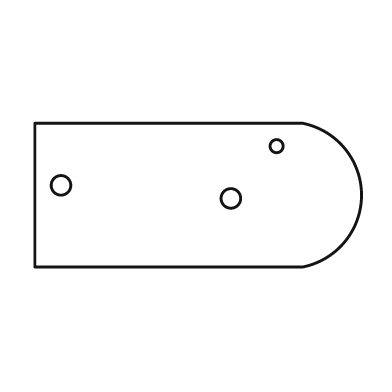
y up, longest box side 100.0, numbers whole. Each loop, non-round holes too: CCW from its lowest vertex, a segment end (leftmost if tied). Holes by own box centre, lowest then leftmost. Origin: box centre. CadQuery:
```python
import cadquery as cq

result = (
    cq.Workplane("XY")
    .moveTo(-50.0, -22.0)
    .lineTo(32.0, -22.0)
    .threePointArc((50.0, 0.0), (32.0, 22.0))
    .lineTo(-50.0, 22.0)
    .close()
    .moveTo(10.0, -1.0)
    .circle(3.0)
    .moveTo(-42.0, 3.0)
    .circle(3.0)
    .moveTo(24.0, 15.0)
    .circle(2.0)
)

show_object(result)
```